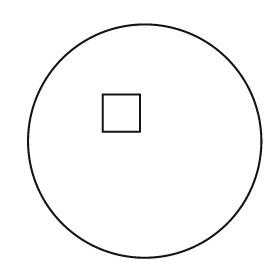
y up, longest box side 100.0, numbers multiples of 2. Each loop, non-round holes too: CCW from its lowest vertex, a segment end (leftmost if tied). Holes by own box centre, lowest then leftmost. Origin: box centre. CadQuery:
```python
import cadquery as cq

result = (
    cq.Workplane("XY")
    .moveTo(0.0, 0.0)
    .circle(50.0)
    .moveTo(-18.0, 4.0)
    .lineTo(-2.0, 4.0)
    .lineTo(-2.0, 20.0)
    .lineTo(-18.0, 20.0)
    .close()
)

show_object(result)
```